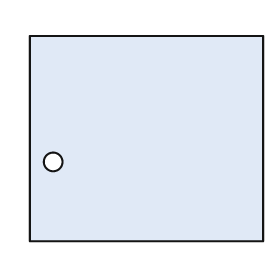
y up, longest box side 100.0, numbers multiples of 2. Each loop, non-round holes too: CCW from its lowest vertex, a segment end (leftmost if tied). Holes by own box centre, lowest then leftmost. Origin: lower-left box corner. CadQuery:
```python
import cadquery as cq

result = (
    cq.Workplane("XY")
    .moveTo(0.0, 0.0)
    .lineTo(100.0, 0.0)
    .lineTo(100.0, 88.0)
    .lineTo(0.0, 88.0)
    .close()
    .moveTo(10.0, 34.0)
    .circle(4.0)
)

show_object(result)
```